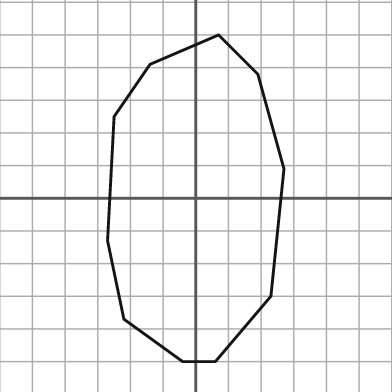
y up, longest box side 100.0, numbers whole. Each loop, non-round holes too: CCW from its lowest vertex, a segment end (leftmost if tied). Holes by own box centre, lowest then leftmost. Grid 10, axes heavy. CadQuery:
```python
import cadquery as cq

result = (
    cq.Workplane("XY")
    .moveTo(-4.0, -50.0)
    .lineTo(6.0, -50.0)
    .lineTo(23.0, -30.0)
    .lineTo(27.0, 9.0)
    .lineTo(19.0, 38.0)
    .lineTo(7.0, 50.0)
    .lineTo(-14.0, 41.0)
    .lineTo(-25.0, 25.0)
    .lineTo(-27.0, -13.0)
    .lineTo(-22.0, -37.0)
    .close()
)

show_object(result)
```